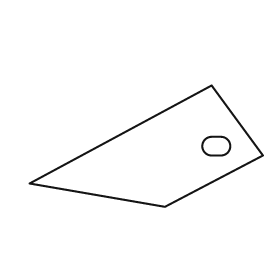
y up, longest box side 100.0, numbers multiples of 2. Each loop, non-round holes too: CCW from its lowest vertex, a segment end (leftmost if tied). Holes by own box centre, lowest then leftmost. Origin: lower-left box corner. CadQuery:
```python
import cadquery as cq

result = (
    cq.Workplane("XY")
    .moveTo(58.0, 0.0)
    .lineTo(100.0, 22.0)
    .lineTo(78.0, 52.0)
    .lineTo(0.0, 10.0)
    .close()
    .moveTo(78.0, 22.0)
    .lineTo(82.0, 22.0)
    .threePointArc((86.0, 26.0), (82.0, 30.0))
    .lineTo(78.0, 30.0)
    .threePointArc((74.0, 26.0), (78.0, 22.0))
    .close()
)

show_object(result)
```